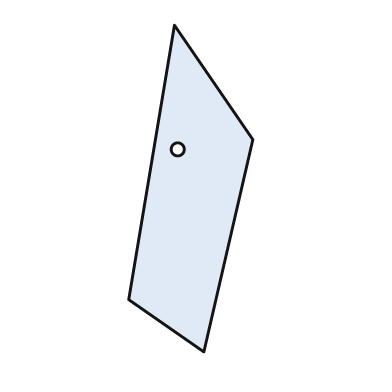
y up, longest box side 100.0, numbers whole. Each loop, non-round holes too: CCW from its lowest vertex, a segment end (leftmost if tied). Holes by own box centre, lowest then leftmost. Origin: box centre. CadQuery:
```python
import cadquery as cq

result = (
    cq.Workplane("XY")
    .moveTo(4.0, -50.0)
    .lineTo(19.0, 15.0)
    .lineTo(-5.0, 50.0)
    .lineTo(-19.0, -34.0)
    .close()
    .moveTo(-4.0, 12.0)
    .circle(2.0)
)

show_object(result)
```